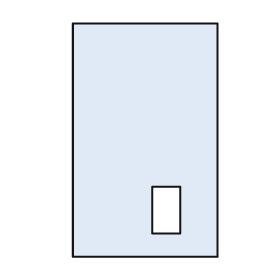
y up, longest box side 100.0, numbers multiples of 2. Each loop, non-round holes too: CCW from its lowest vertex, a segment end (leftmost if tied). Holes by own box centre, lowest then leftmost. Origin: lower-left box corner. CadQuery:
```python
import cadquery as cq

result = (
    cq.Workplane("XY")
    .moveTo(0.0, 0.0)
    .lineTo(62.0, 0.0)
    .lineTo(62.0, 100.0)
    .lineTo(0.0, 100.0)
    .close()
    .moveTo(34.0, 10.0)
    .lineTo(46.0, 10.0)
    .lineTo(46.0, 30.0)
    .lineTo(34.0, 30.0)
    .close()
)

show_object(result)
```